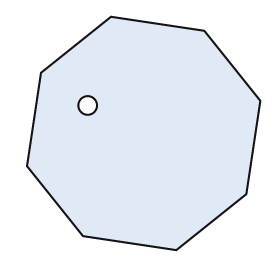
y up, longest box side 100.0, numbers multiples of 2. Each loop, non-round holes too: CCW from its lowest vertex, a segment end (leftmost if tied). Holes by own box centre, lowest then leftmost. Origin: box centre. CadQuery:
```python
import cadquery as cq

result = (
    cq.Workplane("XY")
    .moveTo(14.0, -50.0)
    .lineTo(44.0, -26.0)
    .lineTo(50.0, 14.0)
    .lineTo(26.0, 44.0)
    .lineTo(-14.0, 50.0)
    .lineTo(-44.0, 26.0)
    .lineTo(-50.0, -14.0)
    .lineTo(-26.0, -44.0)
    .close()
    .moveTo(-24.0, 12.0)
    .circle(4.0)
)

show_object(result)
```